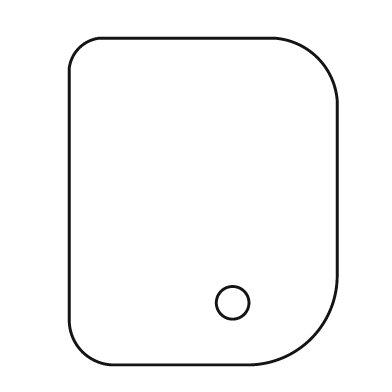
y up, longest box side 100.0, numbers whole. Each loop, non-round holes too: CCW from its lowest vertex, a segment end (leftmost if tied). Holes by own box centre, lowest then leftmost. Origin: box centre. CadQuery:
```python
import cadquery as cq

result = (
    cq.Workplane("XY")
    .moveTo(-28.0, -50.0)
    .lineTo(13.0, -50.0)
    .threePointArc((33.0, -42.0), (41.0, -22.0))
    .lineTo(41.0, 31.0)
    .threePointArc((35.0, 44.0), (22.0, 50.0))
    .lineTo(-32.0, 50.0)
    .threePointArc((-38.0, 47.0), (-41.0, 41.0))
    .lineTo(-41.0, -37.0)
    .threePointArc((-37.0, -46.0), (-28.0, -50.0))
    .close()
    .moveTo(9.0, -31.0)
    .circle(5.0)
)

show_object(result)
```